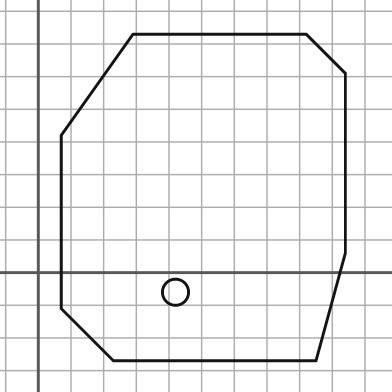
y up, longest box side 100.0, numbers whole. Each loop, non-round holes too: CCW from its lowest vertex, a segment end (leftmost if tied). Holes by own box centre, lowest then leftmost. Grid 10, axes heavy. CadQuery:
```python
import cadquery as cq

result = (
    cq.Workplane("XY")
    .moveTo(23.0, -27.0)
    .lineTo(85.0, -27.0)
    .lineTo(94.0, 6.0)
    .lineTo(94.0, 61.0)
    .lineTo(82.0, 73.0)
    .lineTo(29.0, 73.0)
    .lineTo(7.0, 42.0)
    .lineTo(7.0, -11.0)
    .close()
    .moveTo(42.0, -6.0)
    .circle(4.0)
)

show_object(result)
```